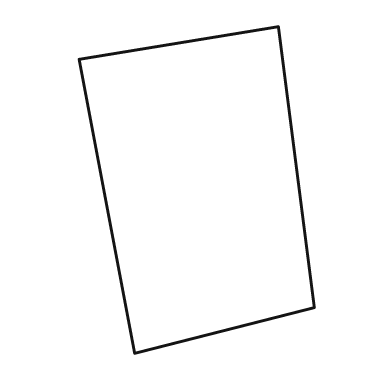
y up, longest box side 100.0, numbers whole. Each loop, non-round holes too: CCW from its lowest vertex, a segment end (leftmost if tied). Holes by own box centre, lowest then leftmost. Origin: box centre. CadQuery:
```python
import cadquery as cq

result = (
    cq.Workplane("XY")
    .moveTo(-19.0, -50.0)
    .lineTo(36.0, -36.0)
    .lineTo(25.0, 50.0)
    .lineTo(-36.0, 40.0)
    .close()
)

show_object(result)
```